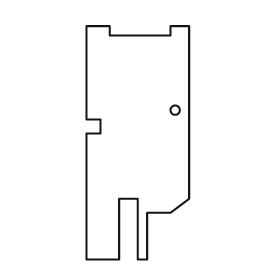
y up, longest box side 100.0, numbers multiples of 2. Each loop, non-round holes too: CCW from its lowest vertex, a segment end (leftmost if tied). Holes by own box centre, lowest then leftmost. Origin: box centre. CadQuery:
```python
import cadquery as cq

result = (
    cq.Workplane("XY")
    .moveTo(-22.0, -50.0)
    .lineTo(-8.0, -50.0)
    .lineTo(-8.0, -24.0)
    .lineTo(0.0, -24.0)
    .lineTo(0.0, -50.0)
    .lineTo(4.0, -50.0)
    .lineTo(4.0, -30.0)
    .lineTo(14.0, -30.0)
    .lineTo(22.0, -24.0)
    .lineTo(22.0, 50.0)
    .lineTo(14.0, 50.0)
    .lineTo(14.0, 46.0)
    .lineTo(-12.0, 46.0)
    .lineTo(-12.0, 50.0)
    .lineTo(-22.0, 50.0)
    .lineTo(-22.0, 10.0)
    .lineTo(-16.0, 10.0)
    .lineTo(-16.0, 4.0)
    .lineTo(-22.0, 4.0)
    .close()
    .moveTo(16.0, 14.0)
    .circle(2.0)
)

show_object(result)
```